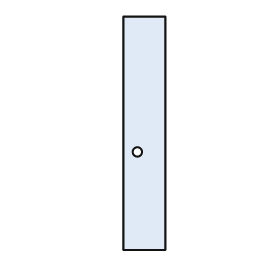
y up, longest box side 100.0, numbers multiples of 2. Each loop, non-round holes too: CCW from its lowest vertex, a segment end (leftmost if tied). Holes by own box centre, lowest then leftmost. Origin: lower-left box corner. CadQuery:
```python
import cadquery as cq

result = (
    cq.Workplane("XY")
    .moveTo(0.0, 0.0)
    .lineTo(18.0, 0.0)
    .lineTo(18.0, 100.0)
    .lineTo(0.0, 100.0)
    .close()
    .moveTo(6.0, 42.0)
    .circle(2.0)
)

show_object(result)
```